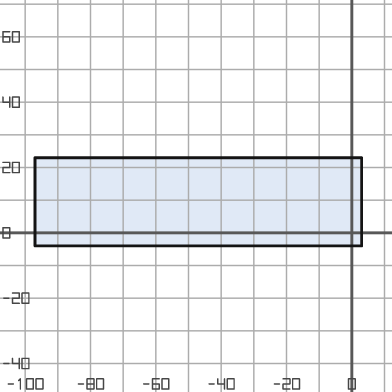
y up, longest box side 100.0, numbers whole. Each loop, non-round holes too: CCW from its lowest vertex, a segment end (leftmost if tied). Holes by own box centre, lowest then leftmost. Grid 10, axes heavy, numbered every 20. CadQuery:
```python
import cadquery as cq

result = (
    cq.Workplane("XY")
    .moveTo(-97.0, -4.0)
    .lineTo(3.0, -4.0)
    .lineTo(3.0, 23.0)
    .lineTo(-97.0, 23.0)
    .close()
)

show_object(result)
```